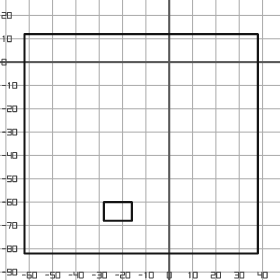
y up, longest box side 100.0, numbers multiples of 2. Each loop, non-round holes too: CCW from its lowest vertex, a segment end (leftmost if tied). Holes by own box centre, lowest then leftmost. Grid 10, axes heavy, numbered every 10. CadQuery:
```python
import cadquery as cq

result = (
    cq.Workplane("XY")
    .moveTo(-62.0, -82.0)
    .lineTo(38.0, -82.0)
    .lineTo(38.0, 12.0)
    .lineTo(-62.0, 12.0)
    .close()
    .moveTo(-28.0, -68.0)
    .lineTo(-16.0, -68.0)
    .lineTo(-16.0, -60.0)
    .lineTo(-28.0, -60.0)
    .close()
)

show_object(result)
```